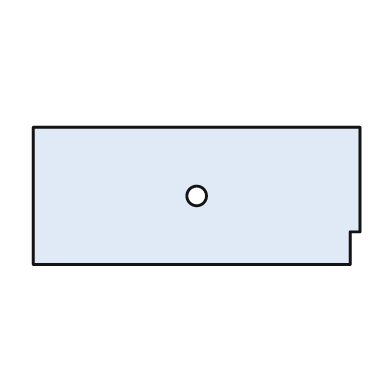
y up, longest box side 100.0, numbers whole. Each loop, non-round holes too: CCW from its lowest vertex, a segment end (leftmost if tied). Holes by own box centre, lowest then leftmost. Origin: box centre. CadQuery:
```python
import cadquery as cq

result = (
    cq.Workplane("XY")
    .moveTo(-50.0, -21.0)
    .lineTo(47.0, -21.0)
    .lineTo(47.0, -11.0)
    .lineTo(50.0, -11.0)
    .lineTo(50.0, 21.0)
    .lineTo(-50.0, 21.0)
    .close()
    .moveTo(0.0, 0.0)
    .circle(3.0)
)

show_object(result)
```